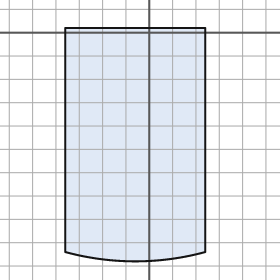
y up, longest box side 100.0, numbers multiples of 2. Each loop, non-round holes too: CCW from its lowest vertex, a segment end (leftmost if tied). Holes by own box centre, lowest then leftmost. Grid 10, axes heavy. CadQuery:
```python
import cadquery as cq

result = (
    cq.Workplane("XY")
    .moveTo(-36.0, -94.0)
    .threePointArc((-6.0, -98.0), (24.0, -94.0))
    .lineTo(24.0, 2.0)
    .lineTo(-36.0, 2.0)
    .close()
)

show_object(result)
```